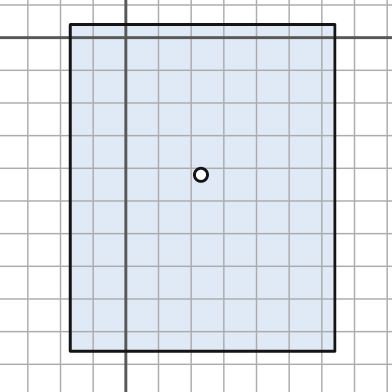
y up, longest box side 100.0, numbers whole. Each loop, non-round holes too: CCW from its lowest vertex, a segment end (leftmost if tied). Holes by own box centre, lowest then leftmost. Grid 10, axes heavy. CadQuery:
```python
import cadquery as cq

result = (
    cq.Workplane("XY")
    .moveTo(-17.0, -96.0)
    .lineTo(64.0, -96.0)
    .lineTo(64.0, 4.0)
    .lineTo(-17.0, 4.0)
    .close()
    .moveTo(23.0, -42.0)
    .circle(2.0)
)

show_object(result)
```